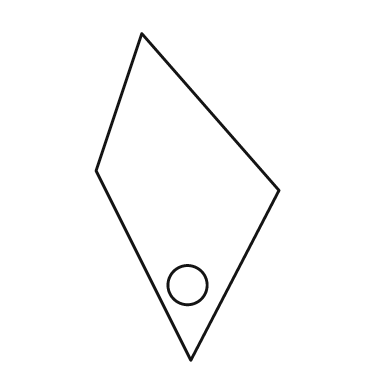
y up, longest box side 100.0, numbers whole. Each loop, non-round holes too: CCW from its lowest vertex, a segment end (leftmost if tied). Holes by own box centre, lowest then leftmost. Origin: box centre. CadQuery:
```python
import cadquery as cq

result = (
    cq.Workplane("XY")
    .moveTo(1.0, -50.0)
    .lineTo(28.0, 2.0)
    .lineTo(-14.0, 50.0)
    .lineTo(-28.0, 8.0)
    .close()
    .moveTo(0.0, -27.0)
    .circle(6.0)
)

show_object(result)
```